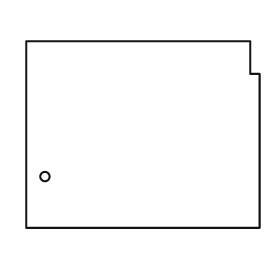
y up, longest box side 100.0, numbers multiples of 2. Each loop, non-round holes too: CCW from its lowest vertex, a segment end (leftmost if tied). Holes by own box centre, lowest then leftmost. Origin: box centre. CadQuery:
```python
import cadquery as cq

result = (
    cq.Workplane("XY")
    .moveTo(-50.0, -40.0)
    .lineTo(50.0, -40.0)
    .lineTo(50.0, 26.0)
    .lineTo(46.0, 26.0)
    .lineTo(46.0, 40.0)
    .lineTo(-50.0, 40.0)
    .close()
    .moveTo(-42.0, -18.0)
    .circle(2.0)
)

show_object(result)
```